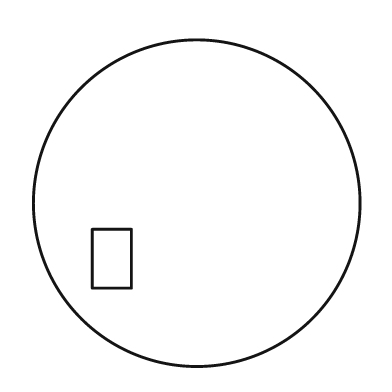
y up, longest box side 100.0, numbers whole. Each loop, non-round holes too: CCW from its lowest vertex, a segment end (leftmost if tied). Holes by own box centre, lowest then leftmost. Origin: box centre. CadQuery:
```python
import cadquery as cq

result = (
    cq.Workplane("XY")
    .moveTo(0.0, 0.0)
    .circle(50.0)
    .moveTo(-32.0, -26.0)
    .lineTo(-20.0, -26.0)
    .lineTo(-20.0, -8.0)
    .lineTo(-32.0, -8.0)
    .close()
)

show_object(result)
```